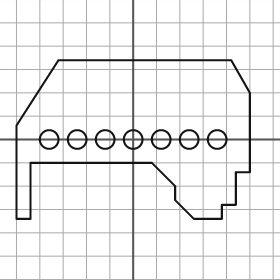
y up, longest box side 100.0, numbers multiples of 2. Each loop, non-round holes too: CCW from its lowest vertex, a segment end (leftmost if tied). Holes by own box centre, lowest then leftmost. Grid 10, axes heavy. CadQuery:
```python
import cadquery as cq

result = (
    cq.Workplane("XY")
    .moveTo(-50.0, -34.0)
    .lineTo(-44.0, -34.0)
    .lineTo(-44.0, -10.0)
    .lineTo(8.0, -10.0)
    .lineTo(18.0, -20.0)
    .lineTo(18.0, -26.0)
    .lineTo(26.0, -34.0)
    .lineTo(38.0, -34.0)
    .lineTo(38.0, -28.0)
    .lineTo(44.0, -28.0)
    .lineTo(44.0, -14.0)
    .lineTo(50.0, -14.0)
    .lineTo(50.0, 20.0)
    .lineTo(42.0, 34.0)
    .lineTo(-32.0, 34.0)
    .lineTo(-50.0, 6.0)
    .close()
    .moveTo(-36.0, 0.0)
    .circle(4.0)
    .moveTo(-24.0, 0.0)
    .circle(4.0)
    .moveTo(-12.0, 0.0)
    .circle(4.0)
    .moveTo(0.0, 0.0)
    .circle(4.0)
    .moveTo(12.0, 0.0)
    .circle(4.0)
    .moveTo(24.0, 0.0)
    .circle(4.0)
    .moveTo(36.0, 0.0)
    .circle(4.0)
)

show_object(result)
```